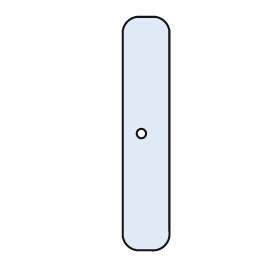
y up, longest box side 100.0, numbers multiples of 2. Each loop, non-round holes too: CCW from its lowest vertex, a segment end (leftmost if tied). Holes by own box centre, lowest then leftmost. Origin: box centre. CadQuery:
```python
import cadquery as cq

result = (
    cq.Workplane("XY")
    .moveTo(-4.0, -50.0)
    .lineTo(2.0, -50.0)
    .threePointArc((8.0, -48.0), (10.0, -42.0))
    .lineTo(10.0, 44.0)
    .threePointArc((8.0, 48.0), (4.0, 50.0))
    .lineTo(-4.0, 50.0)
    .threePointArc((-8.0, 48.0), (-10.0, 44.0))
    .lineTo(-10.0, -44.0)
    .threePointArc((-8.0, -48.0), (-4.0, -50.0))
    .close()
    .moveTo(-2.0, 0.0)
    .circle(2.0)
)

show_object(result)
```